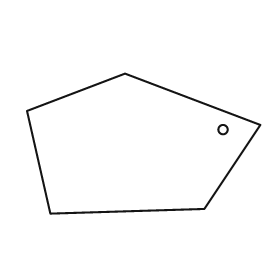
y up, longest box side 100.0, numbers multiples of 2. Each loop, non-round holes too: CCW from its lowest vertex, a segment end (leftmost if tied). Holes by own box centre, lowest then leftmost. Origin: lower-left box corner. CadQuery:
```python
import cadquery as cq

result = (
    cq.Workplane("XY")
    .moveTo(10.0, 0.0)
    .lineTo(76.0, 2.0)
    .lineTo(100.0, 38.0)
    .lineTo(42.0, 60.0)
    .lineTo(0.0, 44.0)
    .close()
    .moveTo(84.0, 36.0)
    .circle(2.0)
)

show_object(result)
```